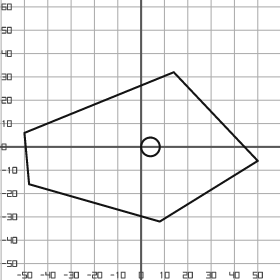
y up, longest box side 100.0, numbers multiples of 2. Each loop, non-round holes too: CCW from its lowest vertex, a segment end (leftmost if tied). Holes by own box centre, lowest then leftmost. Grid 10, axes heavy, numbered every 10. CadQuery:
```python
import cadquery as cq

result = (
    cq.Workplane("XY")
    .moveTo(8.0, -32.0)
    .lineTo(50.0, -6.0)
    .lineTo(14.0, 32.0)
    .lineTo(-50.0, 6.0)
    .lineTo(-48.0, -16.0)
    .close()
    .moveTo(4.0, 0.0)
    .circle(4.0)
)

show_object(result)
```